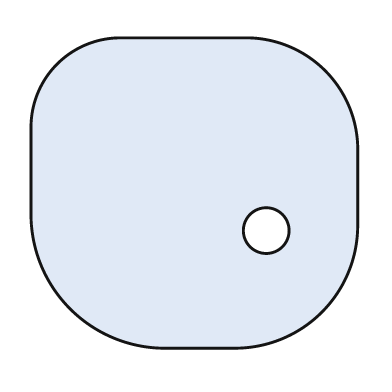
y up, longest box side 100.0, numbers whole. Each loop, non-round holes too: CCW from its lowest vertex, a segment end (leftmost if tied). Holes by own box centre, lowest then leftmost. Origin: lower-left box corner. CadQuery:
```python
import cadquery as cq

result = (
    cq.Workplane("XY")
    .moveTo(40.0, 0.0)
    .lineTo(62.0, 0.0)
    .threePointArc((89.0, 11.0), (100.0, 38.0))
    .lineTo(100.0, 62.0)
    .threePointArc((90.0, 85.0), (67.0, 95.0))
    .lineTo(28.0, 95.0)
    .threePointArc((8.0, 87.0), (0.0, 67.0))
    .lineTo(0.0, 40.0)
    .threePointArc((12.0, 12.0), (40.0, 0.0))
    .close()
    .moveTo(72.0, 36.0)
    .circle(7.0)
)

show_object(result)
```